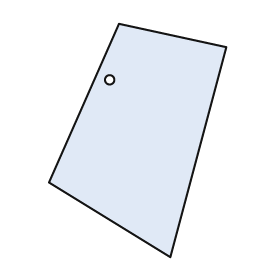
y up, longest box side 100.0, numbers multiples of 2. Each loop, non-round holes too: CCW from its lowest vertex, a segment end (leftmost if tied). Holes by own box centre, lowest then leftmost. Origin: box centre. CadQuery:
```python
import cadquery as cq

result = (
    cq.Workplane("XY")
    .moveTo(14.0, -50.0)
    .lineTo(38.0, 40.0)
    .lineTo(-8.0, 50.0)
    .lineTo(-38.0, -18.0)
    .close()
    .moveTo(-12.0, 26.0)
    .circle(2.0)
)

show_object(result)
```